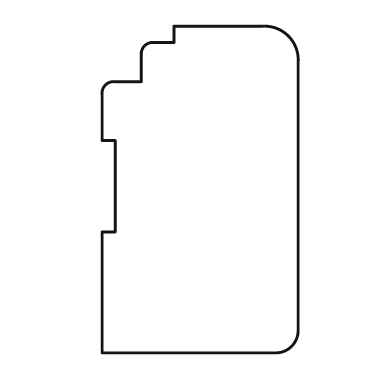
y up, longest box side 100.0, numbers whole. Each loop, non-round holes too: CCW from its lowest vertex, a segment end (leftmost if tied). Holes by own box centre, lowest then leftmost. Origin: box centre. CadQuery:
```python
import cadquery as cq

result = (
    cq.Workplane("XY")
    .moveTo(-30.0, -50.0)
    .lineTo(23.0, -50.0)
    .threePointArc((28.0, -48.0), (30.0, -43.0))
    .lineTo(30.0, 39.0)
    .threePointArc((27.0, 47.0), (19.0, 50.0))
    .lineTo(-8.0, 50.0)
    .lineTo(-8.0, 45.0)
    .lineTo(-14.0, 45.0)
    .threePointArc((-17.0, 44.0), (-18.0, 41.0))
    .lineTo(-18.0, 33.0)
    .lineTo(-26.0, 33.0)
    .threePointArc((-29.0, 32.0), (-30.0, 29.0))
    .lineTo(-30.0, 15.0)
    .lineTo(-26.0, 15.0)
    .lineTo(-26.0, -13.0)
    .lineTo(-30.0, -13.0)
    .close()
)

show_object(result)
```